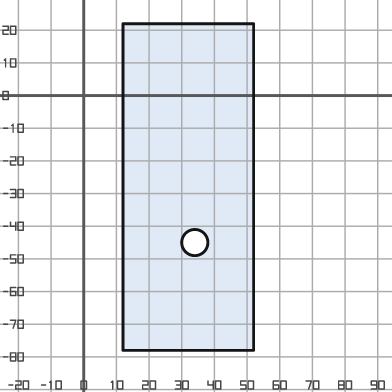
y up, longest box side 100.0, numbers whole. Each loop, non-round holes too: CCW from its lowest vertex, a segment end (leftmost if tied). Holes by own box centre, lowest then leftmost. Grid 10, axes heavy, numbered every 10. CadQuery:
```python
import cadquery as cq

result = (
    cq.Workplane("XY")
    .moveTo(12.0, -78.0)
    .lineTo(52.0, -78.0)
    .lineTo(52.0, 22.0)
    .lineTo(12.0, 22.0)
    .close()
    .moveTo(34.0, -45.0)
    .circle(4.0)
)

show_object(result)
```